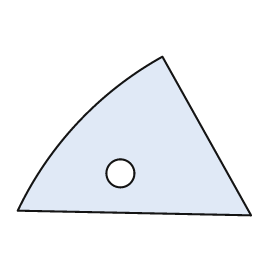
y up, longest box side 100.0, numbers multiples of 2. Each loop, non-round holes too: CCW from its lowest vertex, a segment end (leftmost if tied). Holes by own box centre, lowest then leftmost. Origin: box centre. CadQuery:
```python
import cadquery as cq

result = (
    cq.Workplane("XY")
    .moveTo(50.0, -34.0)
    .lineTo(12.0, 34.0)
    .threePointArc((-24.0, 6.0), (-50.0, -32.0))
    .close()
    .moveTo(-6.0, -16.0)
    .circle(6.0)
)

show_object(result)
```